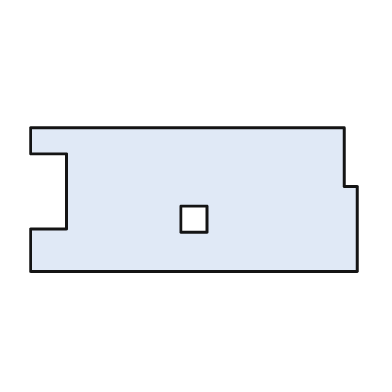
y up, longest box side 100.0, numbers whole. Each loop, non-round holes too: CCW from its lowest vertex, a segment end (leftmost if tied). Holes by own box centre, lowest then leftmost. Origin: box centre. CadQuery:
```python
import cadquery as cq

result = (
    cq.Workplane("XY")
    .moveTo(-50.0, -22.0)
    .lineTo(50.0, -22.0)
    .lineTo(50.0, 4.0)
    .lineTo(46.0, 4.0)
    .lineTo(46.0, 22.0)
    .lineTo(-50.0, 22.0)
    .lineTo(-50.0, 14.0)
    .lineTo(-39.0, 14.0)
    .lineTo(-39.0, -9.0)
    .lineTo(-50.0, -9.0)
    .close()
    .moveTo(-4.0, -10.0)
    .lineTo(4.0, -10.0)
    .lineTo(4.0, -2.0)
    .lineTo(-4.0, -2.0)
    .close()
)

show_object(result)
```